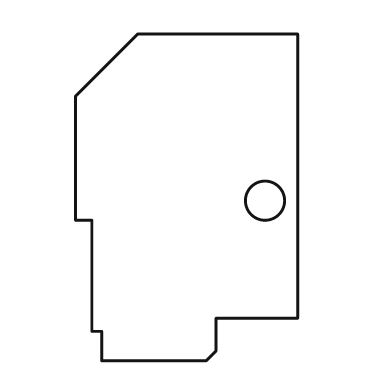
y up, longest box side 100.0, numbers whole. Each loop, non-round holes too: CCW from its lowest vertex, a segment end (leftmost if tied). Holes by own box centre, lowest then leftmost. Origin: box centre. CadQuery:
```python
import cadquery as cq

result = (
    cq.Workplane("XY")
    .moveTo(-26.0, -50.0)
    .lineTo(6.0, -50.0)
    .lineTo(9.0, -47.0)
    .lineTo(9.0, -37.0)
    .lineTo(34.0, -37.0)
    .lineTo(34.0, 50.0)
    .lineTo(-15.0, 50.0)
    .lineTo(-34.0, 31.0)
    .lineTo(-34.0, -7.0)
    .lineTo(-29.0, -7.0)
    .lineTo(-29.0, -41.0)
    .lineTo(-26.0, -41.0)
    .close()
    .moveTo(24.0, -1.0)
    .circle(6.0)
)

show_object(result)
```